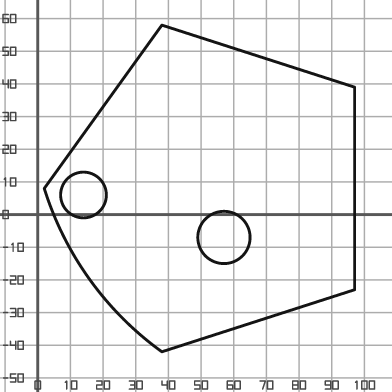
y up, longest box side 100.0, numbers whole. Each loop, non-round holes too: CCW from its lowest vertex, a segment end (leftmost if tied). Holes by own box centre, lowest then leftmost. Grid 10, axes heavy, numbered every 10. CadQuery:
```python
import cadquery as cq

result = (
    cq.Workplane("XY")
    .moveTo(38.0, -42.0)
    .lineTo(97.0, -23.0)
    .lineTo(97.0, 39.0)
    .lineTo(38.0, 58.0)
    .lineTo(2.0, 8.0)
    .threePointArc((16.0, -20.0), (38.0, -42.0))
    .close()
    .moveTo(57.0, -7.0)
    .circle(8.0)
    .moveTo(14.0, 6.0)
    .circle(7.0)
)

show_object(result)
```